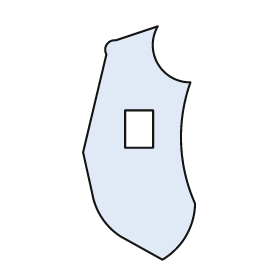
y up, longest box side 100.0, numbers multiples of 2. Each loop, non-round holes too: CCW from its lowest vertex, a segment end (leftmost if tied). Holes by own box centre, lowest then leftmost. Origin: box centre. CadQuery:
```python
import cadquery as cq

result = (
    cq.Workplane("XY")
    .moveTo(10.0, -50.0)
    .threePointArc((20.0, -40.0), (24.0, -26.0))
    .threePointArc((18.0, 0.0), (22.0, 26.0))
    .threePointArc((8.0, 34.0), (8.0, 50.0))
    .lineTo(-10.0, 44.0)
    .threePointArc((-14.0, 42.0), (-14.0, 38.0))
    .lineTo(-24.0, -4.0)
    .lineTo(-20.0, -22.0)
    .threePointArc((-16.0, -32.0), (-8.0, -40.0))
    .close()
    .moveTo(-6.0, -2.0)
    .lineTo(6.0, -2.0)
    .lineTo(6.0, 14.0)
    .lineTo(-6.0, 14.0)
    .close()
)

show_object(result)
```